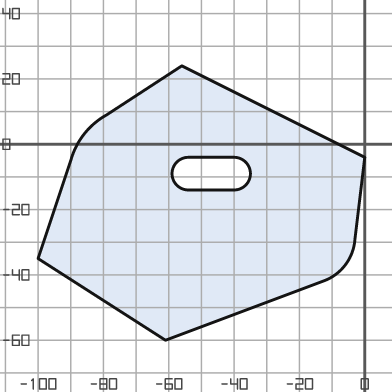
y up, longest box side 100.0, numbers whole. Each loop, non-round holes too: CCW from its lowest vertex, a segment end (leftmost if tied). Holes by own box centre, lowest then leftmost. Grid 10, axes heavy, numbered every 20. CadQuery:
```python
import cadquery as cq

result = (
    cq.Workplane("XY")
    .moveTo(-61.0, -60.0)
    .lineTo(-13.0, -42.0)
    .threePointArc((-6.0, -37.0), (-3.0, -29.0))
    .lineTo(0.0, -4.0)
    .lineTo(-56.0, 24.0)
    .lineTo(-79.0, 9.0)
    .threePointArc((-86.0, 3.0), (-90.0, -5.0))
    .lineTo(-100.0, -35.0)
    .close()
    .moveTo(-54.0, -14.0)
    .lineTo(-40.0, -14.0)
    .threePointArc((-35.0, -9.0), (-40.0, -4.0))
    .lineTo(-54.0, -4.0)
    .threePointArc((-59.0, -9.0), (-54.0, -14.0))
    .close()
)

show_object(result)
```